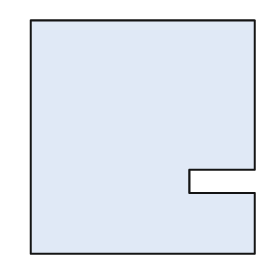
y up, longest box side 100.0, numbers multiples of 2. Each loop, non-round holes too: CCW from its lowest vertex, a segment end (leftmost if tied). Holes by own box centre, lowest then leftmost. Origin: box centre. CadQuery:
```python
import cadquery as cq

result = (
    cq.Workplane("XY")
    .moveTo(-48.0, -50.0)
    .lineTo(48.0, -50.0)
    .lineTo(48.0, -24.0)
    .lineTo(20.0, -24.0)
    .lineTo(20.0, -14.0)
    .lineTo(48.0, -14.0)
    .lineTo(48.0, 50.0)
    .lineTo(-48.0, 50.0)
    .close()
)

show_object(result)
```